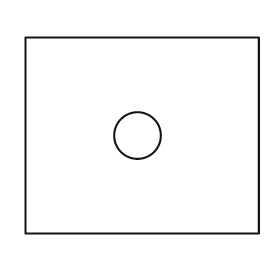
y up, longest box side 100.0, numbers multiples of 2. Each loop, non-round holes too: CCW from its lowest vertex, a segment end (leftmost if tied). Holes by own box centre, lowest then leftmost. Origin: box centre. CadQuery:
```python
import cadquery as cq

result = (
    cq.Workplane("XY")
    .moveTo(-50.0, -42.0)
    .lineTo(50.0, -42.0)
    .lineTo(50.0, 42.0)
    .lineTo(-50.0, 42.0)
    .close()
    .moveTo(-2.0, 0.0)
    .circle(10.0)
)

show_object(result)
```